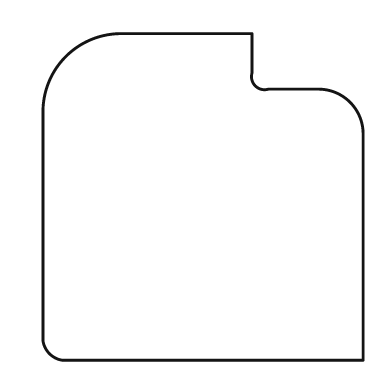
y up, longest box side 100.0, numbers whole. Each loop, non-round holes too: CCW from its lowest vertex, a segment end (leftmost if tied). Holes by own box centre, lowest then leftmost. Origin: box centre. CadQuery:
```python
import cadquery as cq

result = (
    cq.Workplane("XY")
    .moveTo(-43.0, -50.0)
    .lineTo(49.0, -50.0)
    .lineTo(49.0, 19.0)
    .threePointArc((45.0, 29.0), (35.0, 33.0))
    .lineTo(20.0, 33.0)
    .threePointArc((16.0, 34.0), (15.0, 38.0))
    .lineTo(15.0, 50.0)
    .lineTo(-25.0, 50.0)
    .threePointArc((-42.0, 43.0), (-49.0, 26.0))
    .lineTo(-49.0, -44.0)
    .threePointArc((-47.0, -48.0), (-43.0, -50.0))
    .close()
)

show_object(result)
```